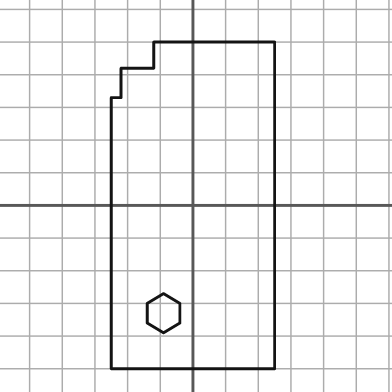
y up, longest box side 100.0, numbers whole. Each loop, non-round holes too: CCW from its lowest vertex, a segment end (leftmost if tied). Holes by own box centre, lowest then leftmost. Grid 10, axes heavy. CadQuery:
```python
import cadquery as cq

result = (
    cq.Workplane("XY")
    .moveTo(-25.0, -50.0)
    .lineTo(25.0, -50.0)
    .lineTo(25.0, 50.0)
    .lineTo(-12.0, 50.0)
    .lineTo(-12.0, 42.0)
    .lineTo(-22.0, 42.0)
    .lineTo(-22.0, 33.0)
    .lineTo(-25.0, 33.0)
    .close()
    .moveTo(-9.0, -39.0)
    .lineTo(-4.0, -36.0)
    .lineTo(-4.0, -30.0)
    .lineTo(-9.0, -27.0)
    .lineTo(-14.0, -30.0)
    .lineTo(-14.0, -36.0)
    .close()
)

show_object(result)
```